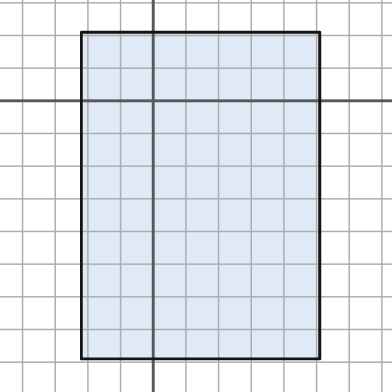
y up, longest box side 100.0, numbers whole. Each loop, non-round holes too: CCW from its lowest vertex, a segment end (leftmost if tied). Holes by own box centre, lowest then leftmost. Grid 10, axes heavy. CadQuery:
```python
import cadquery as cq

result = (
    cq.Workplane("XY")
    .moveTo(-22.0, -79.0)
    .lineTo(51.0, -79.0)
    .lineTo(51.0, 21.0)
    .lineTo(-22.0, 21.0)
    .close()
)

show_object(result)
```